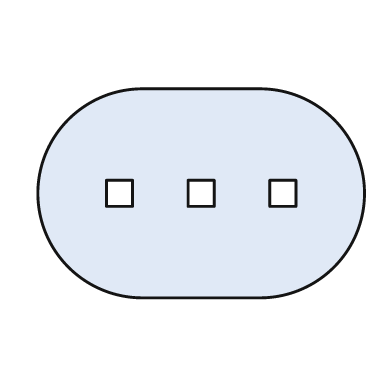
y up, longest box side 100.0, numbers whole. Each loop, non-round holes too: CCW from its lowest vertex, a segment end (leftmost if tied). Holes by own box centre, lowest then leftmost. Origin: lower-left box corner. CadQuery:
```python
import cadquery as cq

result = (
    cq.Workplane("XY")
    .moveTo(32.0, 0.0)
    .lineTo(68.0, 0.0)
    .threePointArc((100.0, 32.0), (68.0, 64.0))
    .lineTo(32.0, 64.0)
    .threePointArc((0.0, 32.0), (32.0, 0.0))
    .close()
    .moveTo(21.0, 28.0)
    .lineTo(29.0, 28.0)
    .lineTo(29.0, 36.0)
    .lineTo(21.0, 36.0)
    .close()
    .moveTo(46.0, 28.0)
    .lineTo(54.0, 28.0)
    .lineTo(54.0, 36.0)
    .lineTo(46.0, 36.0)
    .close()
    .moveTo(71.0, 28.0)
    .lineTo(79.0, 28.0)
    .lineTo(79.0, 36.0)
    .lineTo(71.0, 36.0)
    .close()
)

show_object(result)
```